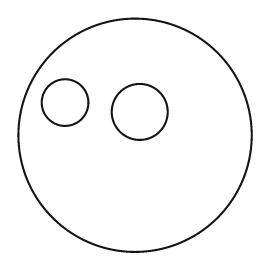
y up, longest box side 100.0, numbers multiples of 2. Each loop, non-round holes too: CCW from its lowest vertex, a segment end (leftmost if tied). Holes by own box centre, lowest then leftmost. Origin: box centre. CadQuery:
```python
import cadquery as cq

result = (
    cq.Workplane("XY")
    .moveTo(0.0, 0.0)
    .circle(50.0)
    .moveTo(2.0, 10.0)
    .circle(12.0)
    .moveTo(-30.0, 14.0)
    .circle(10.0)
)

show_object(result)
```